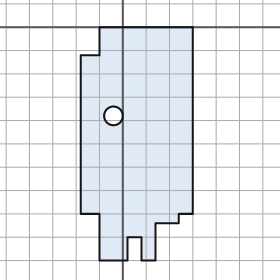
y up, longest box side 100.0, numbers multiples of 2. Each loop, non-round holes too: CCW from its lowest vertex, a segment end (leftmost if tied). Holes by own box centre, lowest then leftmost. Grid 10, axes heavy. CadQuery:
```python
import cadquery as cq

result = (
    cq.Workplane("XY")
    .moveTo(-10.0, -100.0)
    .lineTo(2.0, -100.0)
    .lineTo(2.0, -90.0)
    .lineTo(8.0, -90.0)
    .lineTo(8.0, -100.0)
    .lineTo(14.0, -100.0)
    .lineTo(14.0, -84.0)
    .lineTo(24.0, -84.0)
    .lineTo(24.0, -80.0)
    .lineTo(30.0, -80.0)
    .lineTo(30.0, 0.0)
    .lineTo(-10.0, 0.0)
    .lineTo(-10.0, -12.0)
    .lineTo(-18.0, -12.0)
    .lineTo(-18.0, -80.0)
    .lineTo(-10.0, -80.0)
    .close()
    .moveTo(-4.0, -38.0)
    .circle(4.0)
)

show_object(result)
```